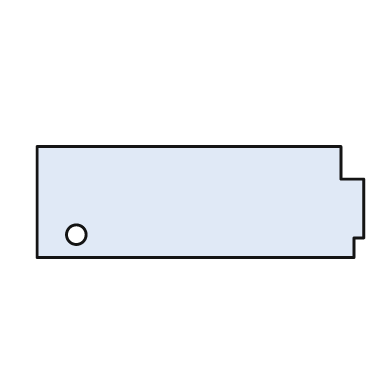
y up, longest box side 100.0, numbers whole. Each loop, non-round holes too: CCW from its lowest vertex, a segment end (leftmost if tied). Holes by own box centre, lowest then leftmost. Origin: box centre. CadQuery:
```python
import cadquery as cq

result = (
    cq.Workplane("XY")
    .moveTo(-50.0, -17.0)
    .lineTo(47.0, -17.0)
    .lineTo(47.0, -11.0)
    .lineTo(50.0, -11.0)
    .lineTo(50.0, 7.0)
    .lineTo(43.0, 7.0)
    .lineTo(43.0, 17.0)
    .lineTo(-50.0, 17.0)
    .close()
    .moveTo(-38.0, -10.0)
    .circle(3.0)
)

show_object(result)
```